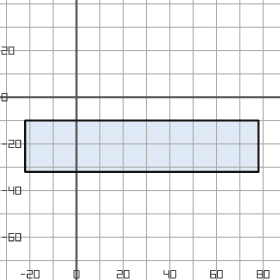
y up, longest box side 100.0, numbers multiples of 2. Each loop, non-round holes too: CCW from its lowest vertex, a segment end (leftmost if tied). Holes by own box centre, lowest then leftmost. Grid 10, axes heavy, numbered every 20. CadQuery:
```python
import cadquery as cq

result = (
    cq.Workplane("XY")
    .moveTo(-22.0, -32.0)
    .lineTo(78.0, -32.0)
    .lineTo(78.0, -10.0)
    .lineTo(-22.0, -10.0)
    .close()
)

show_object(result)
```